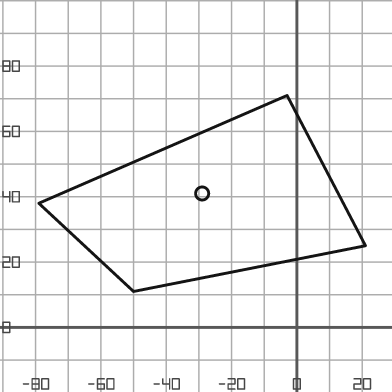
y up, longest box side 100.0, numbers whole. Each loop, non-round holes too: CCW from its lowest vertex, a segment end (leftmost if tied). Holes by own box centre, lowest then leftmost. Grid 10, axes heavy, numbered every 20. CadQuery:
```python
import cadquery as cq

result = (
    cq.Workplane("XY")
    .moveTo(-50.0, 11.0)
    .lineTo(21.0, 25.0)
    .lineTo(-3.0, 71.0)
    .lineTo(-79.0, 38.0)
    .close()
    .moveTo(-29.0, 41.0)
    .circle(2.0)
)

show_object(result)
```